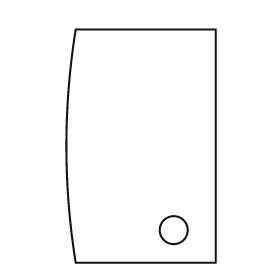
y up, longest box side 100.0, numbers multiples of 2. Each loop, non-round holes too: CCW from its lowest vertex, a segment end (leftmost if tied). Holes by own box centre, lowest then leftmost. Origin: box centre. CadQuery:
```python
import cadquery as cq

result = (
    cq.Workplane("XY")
    .moveTo(-28.0, -50.0)
    .lineTo(32.0, -50.0)
    .lineTo(32.0, 50.0)
    .lineTo(-28.0, 50.0)
    .threePointArc((-32.0, 0.0), (-28.0, -50.0))
    .close()
    .moveTo(14.0, -36.0)
    .circle(6.0)
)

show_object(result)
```